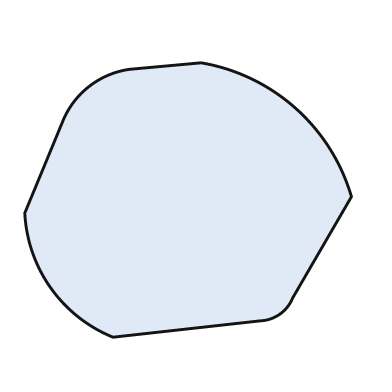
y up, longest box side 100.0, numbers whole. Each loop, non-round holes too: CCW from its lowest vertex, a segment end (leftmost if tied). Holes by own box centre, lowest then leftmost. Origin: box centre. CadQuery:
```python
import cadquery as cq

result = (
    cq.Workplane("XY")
    .moveTo(-23.0, -42.0)
    .lineTo(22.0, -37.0)
    .threePointArc((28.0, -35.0), (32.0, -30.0))
    .lineTo(50.0, 1.0)
    .threePointArc((33.0, 28.0), (4.0, 42.0))
    .lineTo(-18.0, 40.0)
    .threePointArc((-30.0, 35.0), (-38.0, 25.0))
    .lineTo(-50.0, -4.0)
    .threePointArc((-42.0, -27.0), (-23.0, -42.0))
    .close()
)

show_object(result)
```